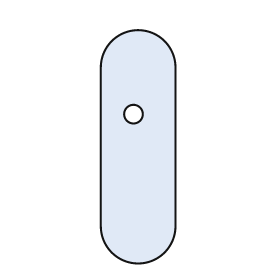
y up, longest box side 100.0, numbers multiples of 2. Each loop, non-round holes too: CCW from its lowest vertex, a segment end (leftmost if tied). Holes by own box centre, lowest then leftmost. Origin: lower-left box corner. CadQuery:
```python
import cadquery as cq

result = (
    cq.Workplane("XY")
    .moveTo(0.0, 16.0)
    .threePointArc((16.0, 0.0), (32.0, 16.0))
    .lineTo(32.0, 84.0)
    .threePointArc((16.0, 100.0), (0.0, 84.0))
    .close()
    .moveTo(14.0, 64.0)
    .circle(4.0)
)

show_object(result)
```